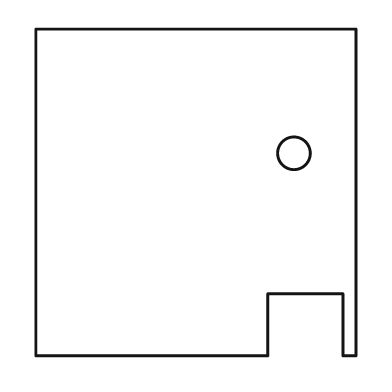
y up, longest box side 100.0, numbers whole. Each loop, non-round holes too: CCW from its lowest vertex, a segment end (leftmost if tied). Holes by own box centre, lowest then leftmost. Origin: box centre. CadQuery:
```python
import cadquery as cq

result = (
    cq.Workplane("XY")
    .moveTo(-49.0, -50.0)
    .lineTo(22.0, -50.0)
    .lineTo(22.0, -31.0)
    .lineTo(45.0, -31.0)
    .lineTo(45.0, -50.0)
    .lineTo(49.0, -50.0)
    .lineTo(49.0, 50.0)
    .lineTo(-49.0, 50.0)
    .close()
    .moveTo(30.0, 12.0)
    .circle(5.0)
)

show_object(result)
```